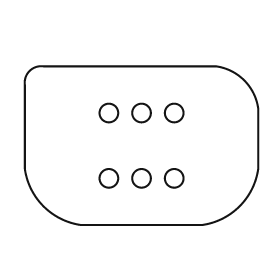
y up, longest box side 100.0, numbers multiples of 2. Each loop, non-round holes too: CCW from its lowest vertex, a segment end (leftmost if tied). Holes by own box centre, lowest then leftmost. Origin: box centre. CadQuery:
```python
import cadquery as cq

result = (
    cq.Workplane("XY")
    .moveTo(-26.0, -34.0)
    .lineTo(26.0, -34.0)
    .threePointArc((42.0, -26.0), (50.0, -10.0))
    .lineTo(50.0, 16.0)
    .threePointArc((44.0, 28.0), (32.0, 34.0))
    .lineTo(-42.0, 34.0)
    .threePointArc((-48.0, 32.0), (-50.0, 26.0))
    .lineTo(-50.0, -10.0)
    .threePointArc((-42.0, -26.0), (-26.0, -34.0))
    .close()
    .moveTo(-14.0, -14.0)
    .circle(4.0)
    .moveTo(0.0, -14.0)
    .circle(4.0)
    .moveTo(14.0, -14.0)
    .circle(4.0)
    .moveTo(-14.0, 14.0)
    .circle(4.0)
    .moveTo(0.0, 14.0)
    .circle(4.0)
    .moveTo(14.0, 14.0)
    .circle(4.0)
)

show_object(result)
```